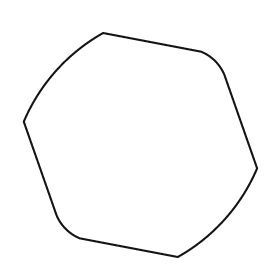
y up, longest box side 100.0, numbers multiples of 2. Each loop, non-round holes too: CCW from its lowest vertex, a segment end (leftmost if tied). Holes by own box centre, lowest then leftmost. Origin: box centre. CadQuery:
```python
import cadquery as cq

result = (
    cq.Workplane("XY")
    .moveTo(16.0, -48.0)
    .threePointArc((36.0, -32.0), (50.0, -10.0))
    .lineTo(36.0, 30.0)
    .threePointArc((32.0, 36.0), (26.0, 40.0))
    .lineTo(-16.0, 48.0)
    .threePointArc((-36.0, 32.0), (-50.0, 10.0))
    .lineTo(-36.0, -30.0)
    .threePointArc((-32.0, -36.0), (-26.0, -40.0))
    .close()
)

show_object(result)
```